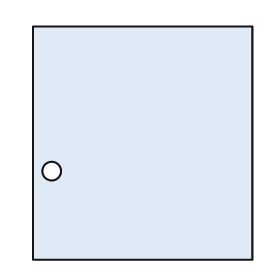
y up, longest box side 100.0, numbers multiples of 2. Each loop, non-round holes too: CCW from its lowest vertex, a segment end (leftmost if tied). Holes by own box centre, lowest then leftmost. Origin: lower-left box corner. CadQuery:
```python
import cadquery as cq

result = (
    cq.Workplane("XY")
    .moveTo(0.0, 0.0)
    .lineTo(94.0, 0.0)
    .lineTo(94.0, 100.0)
    .lineTo(0.0, 100.0)
    .close()
    .moveTo(8.0, 38.0)
    .circle(4.0)
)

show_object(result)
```